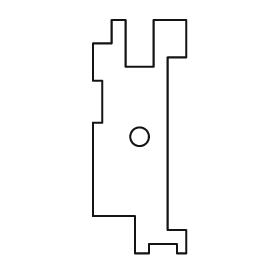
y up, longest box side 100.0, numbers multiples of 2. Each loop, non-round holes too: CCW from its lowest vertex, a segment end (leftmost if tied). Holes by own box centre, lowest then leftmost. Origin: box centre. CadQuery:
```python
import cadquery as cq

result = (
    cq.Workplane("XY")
    .moveTo(-2.0, -50.0)
    .lineTo(4.0, -50.0)
    .lineTo(4.0, -46.0)
    .lineTo(16.0, -46.0)
    .lineTo(16.0, -50.0)
    .lineTo(20.0, -50.0)
    .lineTo(20.0, -40.0)
    .lineTo(12.0, -40.0)
    .lineTo(12.0, 34.0)
    .lineTo(20.0, 34.0)
    .lineTo(20.0, 50.0)
    .lineTo(6.0, 50.0)
    .lineTo(6.0, 30.0)
    .lineTo(-6.0, 30.0)
    .lineTo(-6.0, 50.0)
    .lineTo(-12.0, 50.0)
    .lineTo(-12.0, 40.0)
    .lineTo(-20.0, 40.0)
    .lineTo(-20.0, 24.0)
    .lineTo(-16.0, 24.0)
    .lineTo(-16.0, 6.0)
    .lineTo(-20.0, 6.0)
    .lineTo(-20.0, -34.0)
    .lineTo(-2.0, -34.0)
    .close()
    .moveTo(0.0, 0.0)
    .circle(4.0)
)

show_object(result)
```